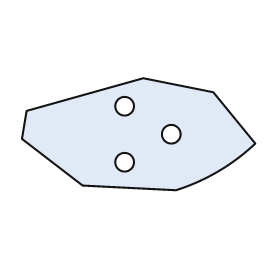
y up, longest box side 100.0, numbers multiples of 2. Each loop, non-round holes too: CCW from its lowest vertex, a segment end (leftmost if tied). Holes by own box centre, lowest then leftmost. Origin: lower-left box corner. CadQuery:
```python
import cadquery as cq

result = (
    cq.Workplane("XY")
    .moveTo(66.0, 0.0)
    .threePointArc((84.0, 8.0), (100.0, 20.0))
    .lineTo(82.0, 42.0)
    .lineTo(52.0, 48.0)
    .lineTo(2.0, 34.0)
    .lineTo(0.0, 22.0)
    .lineTo(26.0, 2.0)
    .close()
    .moveTo(44.0, 12.0)
    .circle(4.0)
    .moveTo(64.0, 24.0)
    .circle(4.0)
    .moveTo(44.0, 36.0)
    .circle(4.0)
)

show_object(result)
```